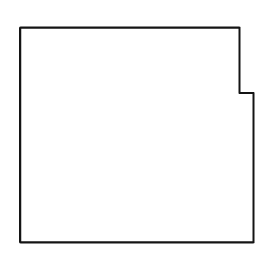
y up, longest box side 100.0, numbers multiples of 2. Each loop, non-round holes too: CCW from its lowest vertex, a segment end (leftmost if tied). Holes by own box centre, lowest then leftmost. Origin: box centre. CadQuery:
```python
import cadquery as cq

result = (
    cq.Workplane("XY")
    .moveTo(-50.0, -46.0)
    .lineTo(50.0, -46.0)
    .lineTo(50.0, 18.0)
    .lineTo(44.0, 18.0)
    .lineTo(44.0, 46.0)
    .lineTo(-50.0, 46.0)
    .close()
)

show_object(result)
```